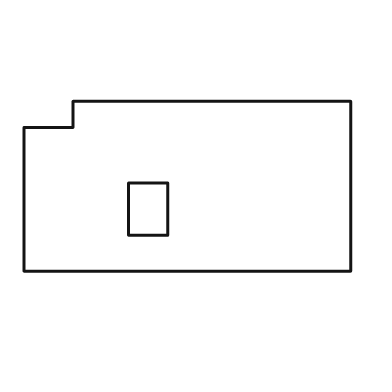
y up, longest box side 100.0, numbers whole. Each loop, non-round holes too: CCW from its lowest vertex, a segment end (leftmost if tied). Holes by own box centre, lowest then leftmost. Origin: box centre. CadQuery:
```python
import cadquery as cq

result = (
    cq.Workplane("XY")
    .moveTo(-50.0, -26.0)
    .lineTo(50.0, -26.0)
    .lineTo(50.0, 26.0)
    .lineTo(-35.0, 26.0)
    .lineTo(-35.0, 18.0)
    .lineTo(-50.0, 18.0)
    .close()
    .moveTo(-18.0, -15.0)
    .lineTo(-6.0, -15.0)
    .lineTo(-6.0, 1.0)
    .lineTo(-18.0, 1.0)
    .close()
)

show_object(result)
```